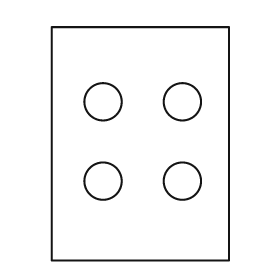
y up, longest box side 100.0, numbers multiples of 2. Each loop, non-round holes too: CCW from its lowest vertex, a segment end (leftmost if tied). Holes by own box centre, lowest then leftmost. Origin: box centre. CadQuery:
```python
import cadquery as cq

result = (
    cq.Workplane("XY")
    .moveTo(-38.0, -50.0)
    .lineTo(38.0, -50.0)
    .lineTo(38.0, 50.0)
    .lineTo(-38.0, 50.0)
    .close()
    .moveTo(-16.0, -16.0)
    .circle(8.0)
    .moveTo(18.0, -16.0)
    .circle(8.0)
    .moveTo(-16.0, 18.0)
    .circle(8.0)
    .moveTo(18.0, 18.0)
    .circle(8.0)
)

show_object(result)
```